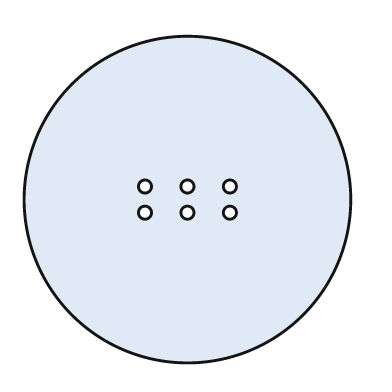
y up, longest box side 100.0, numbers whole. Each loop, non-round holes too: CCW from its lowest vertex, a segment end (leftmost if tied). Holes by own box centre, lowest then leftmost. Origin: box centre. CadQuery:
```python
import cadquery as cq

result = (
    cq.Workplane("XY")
    .moveTo(0.0, 0.0)
    .circle(50.0)
    .moveTo(-13.0, -4.0)
    .circle(2.0)
    .moveTo(0.0, -4.0)
    .circle(2.0)
    .moveTo(13.0, -4.0)
    .circle(2.0)
    .moveTo(-13.0, 4.0)
    .circle(2.0)
    .moveTo(0.0, 4.0)
    .circle(2.0)
    .moveTo(13.0, 4.0)
    .circle(2.0)
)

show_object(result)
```